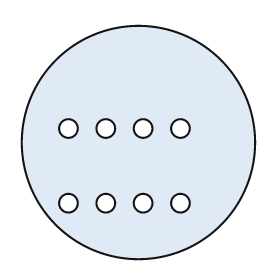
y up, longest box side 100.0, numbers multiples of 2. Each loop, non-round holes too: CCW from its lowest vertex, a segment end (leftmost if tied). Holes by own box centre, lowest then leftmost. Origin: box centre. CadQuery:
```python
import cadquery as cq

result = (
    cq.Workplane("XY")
    .moveTo(0.0, 0.0)
    .circle(50.0)
    .moveTo(-30.0, -26.0)
    .circle(4.0)
    .moveTo(-14.0, -26.0)
    .circle(4.0)
    .moveTo(2.0, -26.0)
    .circle(4.0)
    .moveTo(18.0, -26.0)
    .circle(4.0)
    .moveTo(-30.0, 6.0)
    .circle(4.0)
    .moveTo(-14.0, 6.0)
    .circle(4.0)
    .moveTo(2.0, 6.0)
    .circle(4.0)
    .moveTo(18.0, 6.0)
    .circle(4.0)
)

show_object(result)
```